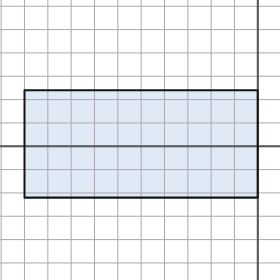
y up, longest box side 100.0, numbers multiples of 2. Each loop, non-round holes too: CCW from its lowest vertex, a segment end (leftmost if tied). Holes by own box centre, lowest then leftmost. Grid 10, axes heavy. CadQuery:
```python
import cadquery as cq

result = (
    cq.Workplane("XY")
    .moveTo(-100.0, -22.0)
    .lineTo(0.0, -22.0)
    .lineTo(0.0, 24.0)
    .lineTo(-100.0, 24.0)
    .close()
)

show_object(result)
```